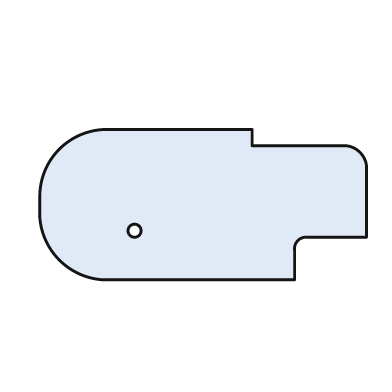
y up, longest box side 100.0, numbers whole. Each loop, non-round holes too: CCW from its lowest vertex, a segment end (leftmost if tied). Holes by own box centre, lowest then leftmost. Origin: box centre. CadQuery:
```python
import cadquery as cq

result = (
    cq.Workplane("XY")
    .moveTo(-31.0, -23.0)
    .lineTo(28.0, -23.0)
    .lineTo(28.0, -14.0)
    .threePointArc((29.0, -11.0), (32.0, -10.0))
    .lineTo(50.0, -10.0)
    .lineTo(50.0, 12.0)
    .threePointArc((48.0, 16.0), (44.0, 18.0))
    .lineTo(15.0, 18.0)
    .lineTo(15.0, 23.0)
    .lineTo(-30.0, 23.0)
    .threePointArc((-44.0, 17.0), (-50.0, 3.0))
    .lineTo(-50.0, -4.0)
    .threePointArc((-44.0, -17.0), (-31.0, -23.0))
    .close()
    .moveTo(-21.0, -8.0)
    .circle(2.0)
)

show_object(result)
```